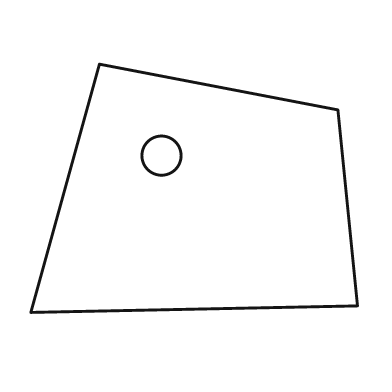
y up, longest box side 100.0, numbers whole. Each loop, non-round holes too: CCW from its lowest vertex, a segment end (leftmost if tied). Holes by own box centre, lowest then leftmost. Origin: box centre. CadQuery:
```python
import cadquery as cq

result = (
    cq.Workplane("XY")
    .moveTo(-50.0, -38.0)
    .lineTo(50.0, -36.0)
    .lineTo(44.0, 24.0)
    .lineTo(-29.0, 38.0)
    .close()
    .moveTo(-10.0, 10.0)
    .circle(6.0)
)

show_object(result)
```